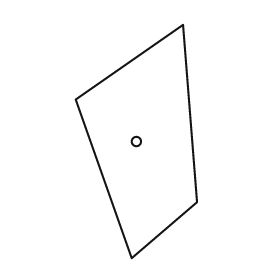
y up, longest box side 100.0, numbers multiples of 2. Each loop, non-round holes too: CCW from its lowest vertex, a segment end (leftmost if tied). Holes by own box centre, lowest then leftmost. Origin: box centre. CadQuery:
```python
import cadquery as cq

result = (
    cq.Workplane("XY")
    .moveTo(-2.0, -50.0)
    .lineTo(26.0, -26.0)
    .lineTo(20.0, 50.0)
    .lineTo(-26.0, 18.0)
    .close()
    .moveTo(0.0, 0.0)
    .circle(2.0)
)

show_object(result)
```